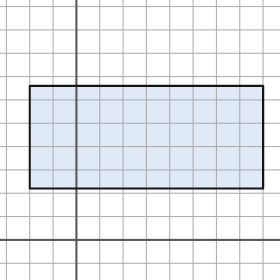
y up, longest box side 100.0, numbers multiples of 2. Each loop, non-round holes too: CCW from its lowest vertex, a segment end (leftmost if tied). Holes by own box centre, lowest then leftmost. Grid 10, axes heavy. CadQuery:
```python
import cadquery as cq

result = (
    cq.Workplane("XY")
    .moveTo(-20.0, 22.0)
    .lineTo(80.0, 22.0)
    .lineTo(80.0, 66.0)
    .lineTo(-20.0, 66.0)
    .close()
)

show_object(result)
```